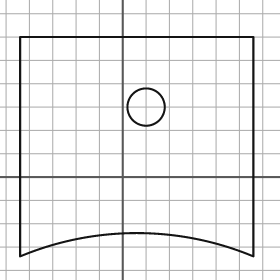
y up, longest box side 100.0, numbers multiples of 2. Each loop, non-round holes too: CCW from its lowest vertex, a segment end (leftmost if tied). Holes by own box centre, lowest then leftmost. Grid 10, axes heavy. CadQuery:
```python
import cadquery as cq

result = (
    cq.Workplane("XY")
    .moveTo(-44.0, -34.0)
    .threePointArc((6.0, -24.0), (56.0, -34.0))
    .lineTo(56.0, 60.0)
    .lineTo(-44.0, 60.0)
    .close()
    .moveTo(10.0, 30.0)
    .circle(8.0)
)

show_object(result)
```